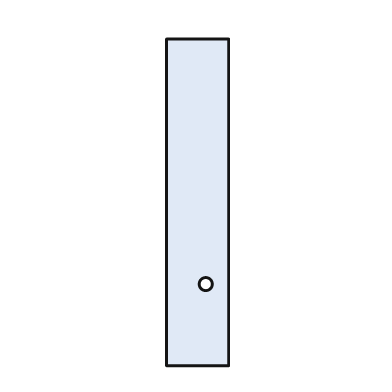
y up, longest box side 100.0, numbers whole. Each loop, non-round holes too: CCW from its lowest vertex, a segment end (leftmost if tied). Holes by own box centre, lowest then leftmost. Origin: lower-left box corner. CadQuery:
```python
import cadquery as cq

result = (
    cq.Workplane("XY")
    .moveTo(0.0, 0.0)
    .lineTo(19.0, 0.0)
    .lineTo(19.0, 100.0)
    .lineTo(0.0, 100.0)
    .close()
    .moveTo(12.0, 25.0)
    .circle(2.0)
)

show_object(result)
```